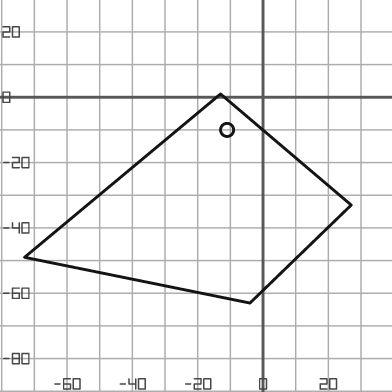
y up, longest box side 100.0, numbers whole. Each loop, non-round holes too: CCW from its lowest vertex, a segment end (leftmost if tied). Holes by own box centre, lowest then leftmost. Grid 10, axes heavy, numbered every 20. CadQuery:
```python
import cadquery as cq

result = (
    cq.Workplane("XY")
    .moveTo(-4.0, -63.0)
    .lineTo(27.0, -33.0)
    .lineTo(-13.0, 1.0)
    .lineTo(-73.0, -49.0)
    .close()
    .moveTo(-11.0, -10.0)
    .circle(2.0)
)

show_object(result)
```